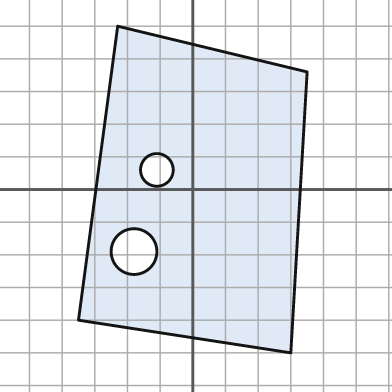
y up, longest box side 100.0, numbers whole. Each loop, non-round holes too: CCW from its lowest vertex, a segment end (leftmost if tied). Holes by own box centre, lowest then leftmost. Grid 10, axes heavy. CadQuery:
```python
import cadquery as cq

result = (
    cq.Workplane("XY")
    .moveTo(30.0, -50.0)
    .lineTo(35.0, 36.0)
    .lineTo(-23.0, 50.0)
    .lineTo(-35.0, -40.0)
    .close()
    .moveTo(-18.0, -19.0)
    .circle(7.0)
    .moveTo(-11.0, 6.0)
    .circle(5.0)
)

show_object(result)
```